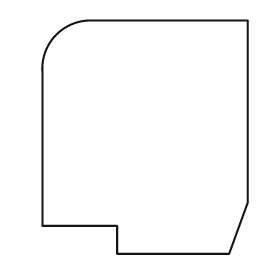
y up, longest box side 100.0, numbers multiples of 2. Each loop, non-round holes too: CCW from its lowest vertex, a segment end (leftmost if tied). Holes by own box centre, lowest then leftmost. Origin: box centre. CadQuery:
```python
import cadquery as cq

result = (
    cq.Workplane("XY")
    .moveTo(-12.0, -50.0)
    .lineTo(36.0, -50.0)
    .lineTo(44.0, -28.0)
    .lineTo(44.0, 50.0)
    .lineTo(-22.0, 50.0)
    .threePointArc((-38.0, 44.0), (-44.0, 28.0))
    .lineTo(-44.0, -38.0)
    .lineTo(-12.0, -38.0)
    .close()
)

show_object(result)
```